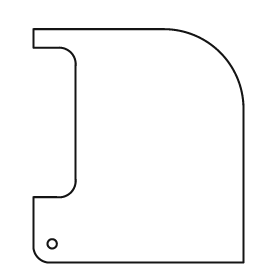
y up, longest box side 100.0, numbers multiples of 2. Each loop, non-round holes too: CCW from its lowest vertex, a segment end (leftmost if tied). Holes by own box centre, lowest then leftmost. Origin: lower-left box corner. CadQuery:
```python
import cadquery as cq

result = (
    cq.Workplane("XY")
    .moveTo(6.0, 0.0)
    .lineTo(90.0, 0.0)
    .lineTo(90.0, 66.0)
    .threePointArc((80.0, 90.0), (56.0, 100.0))
    .lineTo(0.0, 100.0)
    .lineTo(0.0, 92.0)
    .lineTo(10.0, 92.0)
    .threePointArc((16.0, 90.0), (18.0, 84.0))
    .lineTo(18.0, 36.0)
    .threePointArc((16.0, 30.0), (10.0, 28.0))
    .lineTo(0.0, 28.0)
    .lineTo(0.0, 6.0)
    .threePointArc((2.0, 2.0), (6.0, 0.0))
    .close()
    .moveTo(8.0, 8.0)
    .circle(2.0)
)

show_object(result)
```